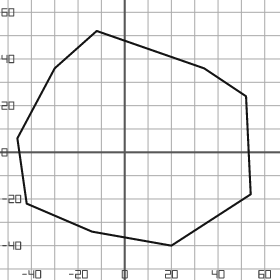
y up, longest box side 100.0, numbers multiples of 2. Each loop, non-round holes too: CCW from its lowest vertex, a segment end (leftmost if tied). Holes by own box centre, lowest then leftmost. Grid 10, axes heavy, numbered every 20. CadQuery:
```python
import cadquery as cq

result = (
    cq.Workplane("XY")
    .moveTo(20.0, -40.0)
    .lineTo(54.0, -18.0)
    .lineTo(52.0, 24.0)
    .lineTo(34.0, 36.0)
    .lineTo(-12.0, 52.0)
    .lineTo(-30.0, 36.0)
    .lineTo(-46.0, 6.0)
    .lineTo(-42.0, -22.0)
    .lineTo(-14.0, -34.0)
    .close()
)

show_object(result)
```